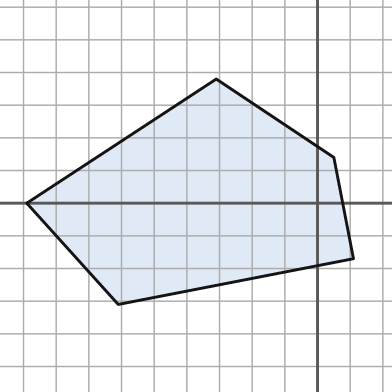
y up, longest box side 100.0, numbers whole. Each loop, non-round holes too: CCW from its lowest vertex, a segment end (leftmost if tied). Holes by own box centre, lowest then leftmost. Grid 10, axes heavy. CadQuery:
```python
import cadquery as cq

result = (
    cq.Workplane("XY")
    .moveTo(-61.0, -31.0)
    .lineTo(11.0, -17.0)
    .lineTo(5.0, 14.0)
    .lineTo(-31.0, 38.0)
    .lineTo(-89.0, 0.0)
    .close()
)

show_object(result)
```